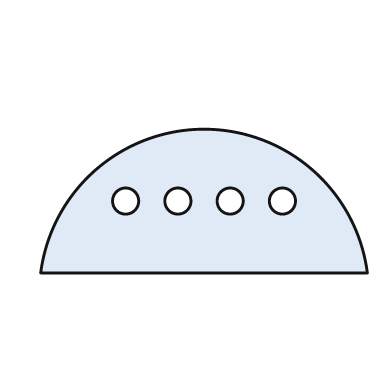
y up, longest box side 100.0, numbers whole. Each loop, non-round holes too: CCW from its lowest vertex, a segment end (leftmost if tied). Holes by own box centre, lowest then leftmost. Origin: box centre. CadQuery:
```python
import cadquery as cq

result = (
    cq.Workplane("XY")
    .moveTo(-50.0, -22.0)
    .lineTo(50.0, -22.0)
    .threePointArc((0.0, 22.0), (-50.0, -22.0))
    .close()
    .moveTo(-24.0, 0.0)
    .circle(4.0)
    .moveTo(-8.0, 0.0)
    .circle(4.0)
    .moveTo(8.0, 0.0)
    .circle(4.0)
    .moveTo(24.0, 0.0)
    .circle(4.0)
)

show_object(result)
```